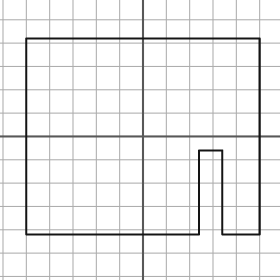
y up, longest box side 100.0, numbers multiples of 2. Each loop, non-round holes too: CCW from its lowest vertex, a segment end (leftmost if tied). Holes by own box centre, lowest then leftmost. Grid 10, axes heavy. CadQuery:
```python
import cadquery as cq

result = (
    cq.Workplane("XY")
    .moveTo(-50.0, -42.0)
    .lineTo(24.0, -42.0)
    .lineTo(24.0, -6.0)
    .lineTo(34.0, -6.0)
    .lineTo(34.0, -42.0)
    .lineTo(50.0, -42.0)
    .lineTo(50.0, 42.0)
    .lineTo(-50.0, 42.0)
    .close()
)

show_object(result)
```